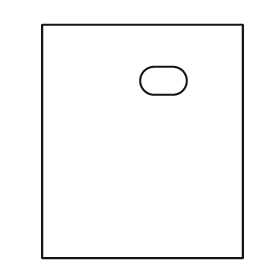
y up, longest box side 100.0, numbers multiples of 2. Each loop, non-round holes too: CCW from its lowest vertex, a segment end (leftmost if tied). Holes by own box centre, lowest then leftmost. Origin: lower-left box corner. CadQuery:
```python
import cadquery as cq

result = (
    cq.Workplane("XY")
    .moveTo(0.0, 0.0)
    .lineTo(86.0, 0.0)
    .lineTo(86.0, 100.0)
    .lineTo(0.0, 100.0)
    .close()
    .moveTo(48.0, 70.0)
    .lineTo(56.0, 70.0)
    .threePointArc((62.0, 76.0), (56.0, 82.0))
    .lineTo(48.0, 82.0)
    .threePointArc((42.0, 76.0), (48.0, 70.0))
    .close()
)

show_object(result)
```